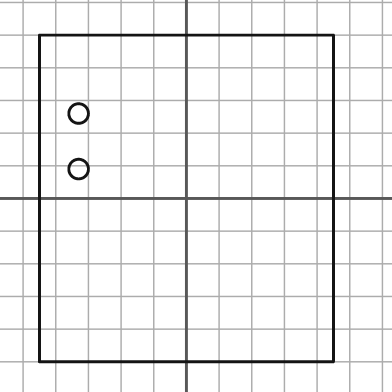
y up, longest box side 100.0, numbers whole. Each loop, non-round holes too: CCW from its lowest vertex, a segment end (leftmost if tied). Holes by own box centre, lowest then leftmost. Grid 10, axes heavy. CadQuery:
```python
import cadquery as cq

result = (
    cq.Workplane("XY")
    .moveTo(-45.0, -50.0)
    .lineTo(45.0, -50.0)
    .lineTo(45.0, 50.0)
    .lineTo(-45.0, 50.0)
    .close()
    .moveTo(-33.0, 9.0)
    .circle(3.0)
    .moveTo(-33.0, 26.0)
    .circle(3.0)
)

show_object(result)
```